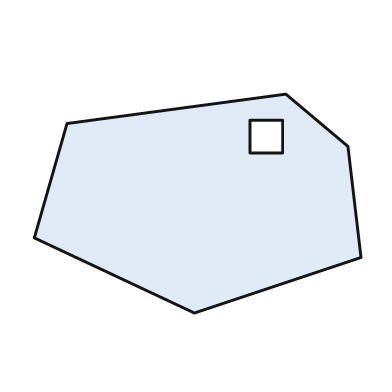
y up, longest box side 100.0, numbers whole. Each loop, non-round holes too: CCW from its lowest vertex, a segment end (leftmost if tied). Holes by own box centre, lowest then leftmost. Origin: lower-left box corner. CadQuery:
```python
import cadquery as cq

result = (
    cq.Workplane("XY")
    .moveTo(49.0, 0.0)
    .lineTo(100.0, 17.0)
    .lineTo(96.0, 51.0)
    .lineTo(77.0, 67.0)
    .lineTo(10.0, 58.0)
    .lineTo(0.0, 23.0)
    .close()
    .moveTo(66.0, 49.0)
    .lineTo(76.0, 49.0)
    .lineTo(76.0, 59.0)
    .lineTo(66.0, 59.0)
    .close()
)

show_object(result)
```